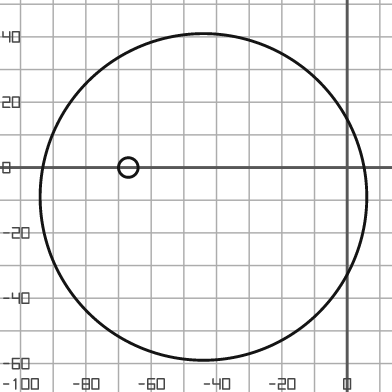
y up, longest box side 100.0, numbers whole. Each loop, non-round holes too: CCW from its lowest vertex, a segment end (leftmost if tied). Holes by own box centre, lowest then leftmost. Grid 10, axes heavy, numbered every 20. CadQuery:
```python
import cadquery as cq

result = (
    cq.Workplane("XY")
    .moveTo(-44.0, -9.0)
    .circle(50.0)
    .moveTo(-67.0, 0.0)
    .circle(3.0)
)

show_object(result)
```